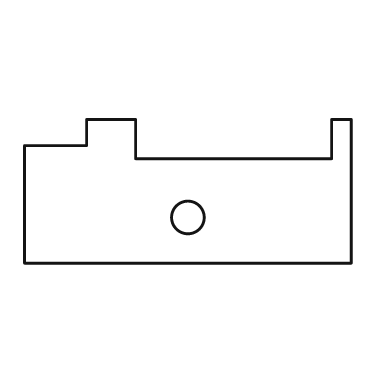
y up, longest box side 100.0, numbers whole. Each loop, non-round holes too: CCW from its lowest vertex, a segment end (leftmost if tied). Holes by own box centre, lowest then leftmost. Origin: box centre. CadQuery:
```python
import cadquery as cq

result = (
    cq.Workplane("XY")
    .moveTo(-50.0, -22.0)
    .lineTo(50.0, -22.0)
    .lineTo(50.0, 22.0)
    .lineTo(44.0, 22.0)
    .lineTo(44.0, 10.0)
    .lineTo(-16.0, 10.0)
    .lineTo(-16.0, 22.0)
    .lineTo(-31.0, 22.0)
    .lineTo(-31.0, 14.0)
    .lineTo(-50.0, 14.0)
    .close()
    .moveTo(0.0, -8.0)
    .circle(5.0)
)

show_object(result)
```